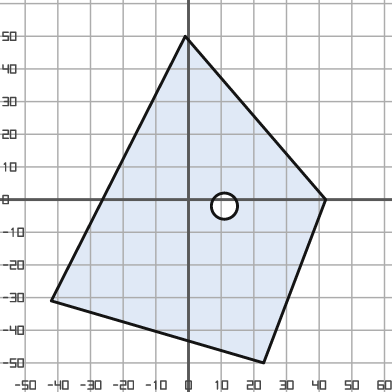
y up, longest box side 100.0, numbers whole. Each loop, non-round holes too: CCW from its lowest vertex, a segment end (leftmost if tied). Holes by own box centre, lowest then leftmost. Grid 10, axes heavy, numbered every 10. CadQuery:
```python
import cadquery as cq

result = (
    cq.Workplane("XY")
    .moveTo(23.0, -50.0)
    .lineTo(42.0, 0.0)
    .lineTo(-1.0, 50.0)
    .lineTo(-42.0, -31.0)
    .close()
    .moveTo(11.0, -2.0)
    .circle(4.0)
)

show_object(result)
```